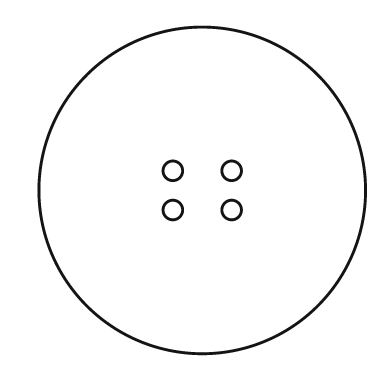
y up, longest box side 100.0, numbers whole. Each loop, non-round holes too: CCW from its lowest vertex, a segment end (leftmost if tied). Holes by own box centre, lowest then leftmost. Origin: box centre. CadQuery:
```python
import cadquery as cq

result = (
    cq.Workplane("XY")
    .moveTo(0.0, 0.0)
    .circle(50.0)
    .moveTo(-9.0, -6.0)
    .circle(3.0)
    .moveTo(9.0, -6.0)
    .circle(3.0)
    .moveTo(-9.0, 6.0)
    .circle(3.0)
    .moveTo(9.0, 6.0)
    .circle(3.0)
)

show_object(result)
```